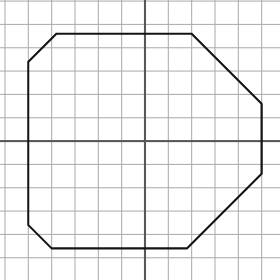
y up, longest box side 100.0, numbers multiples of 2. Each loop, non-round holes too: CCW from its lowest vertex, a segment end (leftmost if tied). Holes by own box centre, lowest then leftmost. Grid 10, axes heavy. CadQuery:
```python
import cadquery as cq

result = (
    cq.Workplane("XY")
    .moveTo(-40.0, -46.0)
    .lineTo(18.0, -46.0)
    .lineTo(50.0, -14.0)
    .lineTo(50.0, 16.0)
    .lineTo(20.0, 46.0)
    .lineTo(-38.0, 46.0)
    .lineTo(-50.0, 34.0)
    .lineTo(-50.0, -36.0)
    .close()
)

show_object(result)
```